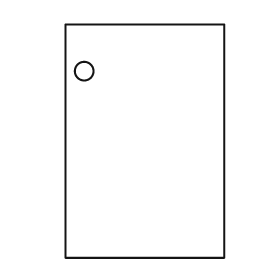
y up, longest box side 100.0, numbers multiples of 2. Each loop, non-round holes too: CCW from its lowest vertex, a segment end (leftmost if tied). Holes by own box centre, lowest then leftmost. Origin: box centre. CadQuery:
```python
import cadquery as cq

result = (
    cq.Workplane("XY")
    .moveTo(-34.0, -50.0)
    .lineTo(34.0, -50.0)
    .lineTo(34.0, 50.0)
    .lineTo(-34.0, 50.0)
    .close()
    .moveTo(-26.0, 30.0)
    .circle(4.0)
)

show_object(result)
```